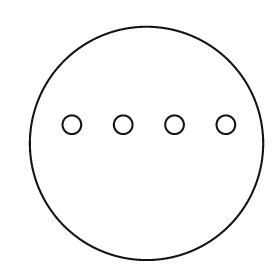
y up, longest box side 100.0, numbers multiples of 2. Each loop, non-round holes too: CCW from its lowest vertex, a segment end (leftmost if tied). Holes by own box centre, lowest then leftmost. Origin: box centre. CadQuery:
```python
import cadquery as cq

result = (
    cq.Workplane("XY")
    .moveTo(0.0, 0.0)
    .circle(50.0)
    .moveTo(-32.0, 8.0)
    .circle(4.0)
    .moveTo(-10.0, 8.0)
    .circle(4.0)
    .moveTo(12.0, 8.0)
    .circle(4.0)
    .moveTo(34.0, 8.0)
    .circle(4.0)
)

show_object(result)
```